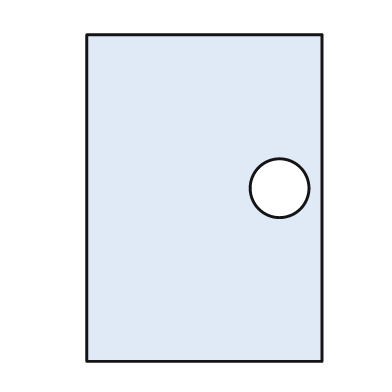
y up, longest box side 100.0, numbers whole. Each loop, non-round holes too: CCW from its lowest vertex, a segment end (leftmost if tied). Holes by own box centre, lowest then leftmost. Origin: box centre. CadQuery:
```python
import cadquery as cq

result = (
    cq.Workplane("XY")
    .moveTo(-36.0, -50.0)
    .lineTo(36.0, -50.0)
    .lineTo(36.0, 50.0)
    .lineTo(-36.0, 50.0)
    .close()
    .moveTo(23.0, 3.0)
    .circle(9.0)
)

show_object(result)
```